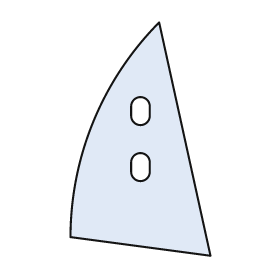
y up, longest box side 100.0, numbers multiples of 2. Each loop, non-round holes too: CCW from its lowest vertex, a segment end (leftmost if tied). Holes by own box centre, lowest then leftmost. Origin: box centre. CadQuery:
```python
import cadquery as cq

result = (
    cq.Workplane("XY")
    .moveTo(30.0, -50.0)
    .lineTo(8.0, 50.0)
    .threePointArc((-20.0, 8.0), (-30.0, -42.0))
    .close()
    .moveTo(-4.0, -14.0)
    .threePointArc((0.0, -18.0), (4.0, -14.0))
    .lineTo(4.0, -10.0)
    .threePointArc((0.0, -6.0), (-4.0, -10.0))
    .close()
    .moveTo(-4.0, 10.0)
    .threePointArc((0.0, 6.0), (4.0, 10.0))
    .lineTo(4.0, 14.0)
    .threePointArc((0.0, 18.0), (-4.0, 14.0))
    .close()
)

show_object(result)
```